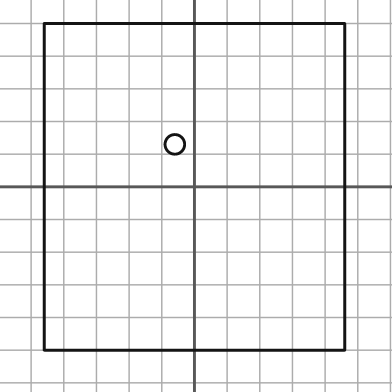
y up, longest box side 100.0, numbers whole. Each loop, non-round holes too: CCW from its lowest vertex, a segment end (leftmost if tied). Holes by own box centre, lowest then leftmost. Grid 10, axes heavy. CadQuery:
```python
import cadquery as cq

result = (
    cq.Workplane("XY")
    .moveTo(-46.0, -50.0)
    .lineTo(46.0, -50.0)
    .lineTo(46.0, 50.0)
    .lineTo(-46.0, 50.0)
    .close()
    .moveTo(-6.0, 13.0)
    .circle(3.0)
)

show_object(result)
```